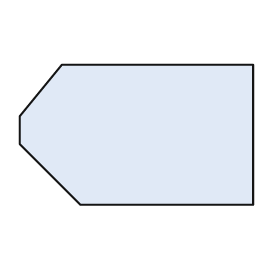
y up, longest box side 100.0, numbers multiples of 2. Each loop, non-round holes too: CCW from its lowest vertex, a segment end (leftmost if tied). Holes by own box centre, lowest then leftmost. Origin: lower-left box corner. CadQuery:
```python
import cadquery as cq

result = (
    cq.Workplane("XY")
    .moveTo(26.0, 0.0)
    .lineTo(100.0, 0.0)
    .lineTo(100.0, 60.0)
    .lineTo(18.0, 60.0)
    .lineTo(0.0, 38.0)
    .lineTo(0.0, 26.0)
    .close()
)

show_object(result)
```